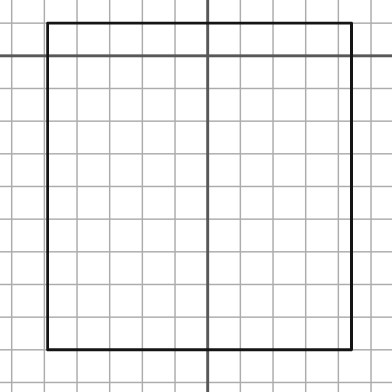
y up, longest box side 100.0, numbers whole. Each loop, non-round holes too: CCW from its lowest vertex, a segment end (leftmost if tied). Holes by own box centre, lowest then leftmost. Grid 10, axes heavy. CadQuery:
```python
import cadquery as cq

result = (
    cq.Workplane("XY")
    .moveTo(-49.0, -90.0)
    .lineTo(44.0, -90.0)
    .lineTo(44.0, 10.0)
    .lineTo(-49.0, 10.0)
    .close()
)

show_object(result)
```